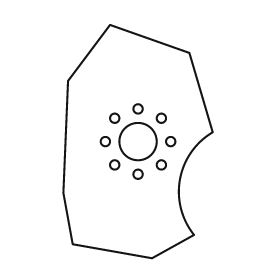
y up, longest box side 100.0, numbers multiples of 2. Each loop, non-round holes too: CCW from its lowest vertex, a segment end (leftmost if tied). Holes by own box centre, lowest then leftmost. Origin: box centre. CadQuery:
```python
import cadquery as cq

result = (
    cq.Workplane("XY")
    .moveTo(6.0, -50.0)
    .lineTo(24.0, -40.0)
    .threePointArc((18.0, -16.0), (32.0, 4.0))
    .lineTo(22.0, 38.0)
    .lineTo(-12.0, 50.0)
    .lineTo(-30.0, 26.0)
    .lineTo(-32.0, -22.0)
    .lineTo(-28.0, -44.0)
    .close()
    .moveTo(0.0, -14.0)
    .circle(2.0)
    .moveTo(-10.0, -10.0)
    .circle(2.0)
    .moveTo(10.0, -10.0)
    .circle(2.0)
    .moveTo(-14.0, 0.0)
    .circle(2.0)
    .moveTo(0.0, 0.0)
    .circle(8.0)
    .moveTo(14.0, 0.0)
    .circle(2.0)
    .moveTo(-10.0, 10.0)
    .circle(2.0)
    .moveTo(10.0, 10.0)
    .circle(2.0)
    .moveTo(0.0, 14.0)
    .circle(2.0)
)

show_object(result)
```